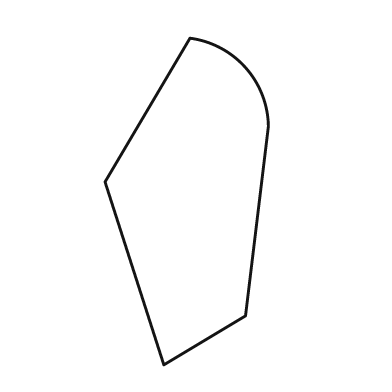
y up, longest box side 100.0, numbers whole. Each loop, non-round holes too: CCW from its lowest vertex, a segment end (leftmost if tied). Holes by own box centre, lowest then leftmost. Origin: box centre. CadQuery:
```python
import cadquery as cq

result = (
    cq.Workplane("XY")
    .moveTo(-7.0, -50.0)
    .lineTo(18.0, -35.0)
    .lineTo(25.0, 23.0)
    .threePointArc((18.0, 41.0), (1.0, 50.0))
    .lineTo(-25.0, 6.0)
    .close()
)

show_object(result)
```